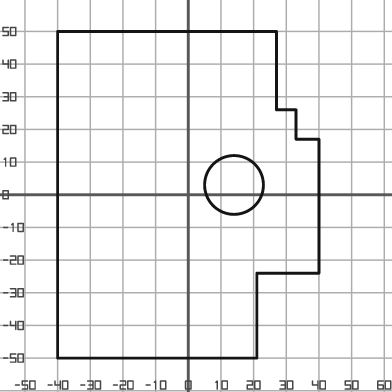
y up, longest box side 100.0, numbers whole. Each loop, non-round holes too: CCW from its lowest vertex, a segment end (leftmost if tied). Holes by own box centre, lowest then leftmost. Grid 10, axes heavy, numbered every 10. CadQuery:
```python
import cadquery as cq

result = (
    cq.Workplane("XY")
    .moveTo(-40.0, -50.0)
    .lineTo(21.0, -50.0)
    .lineTo(21.0, -24.0)
    .lineTo(40.0, -24.0)
    .lineTo(40.0, 17.0)
    .lineTo(33.0, 17.0)
    .lineTo(33.0, 26.0)
    .lineTo(27.0, 26.0)
    .lineTo(27.0, 50.0)
    .lineTo(-40.0, 50.0)
    .close()
    .moveTo(14.0, 3.0)
    .circle(9.0)
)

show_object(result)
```